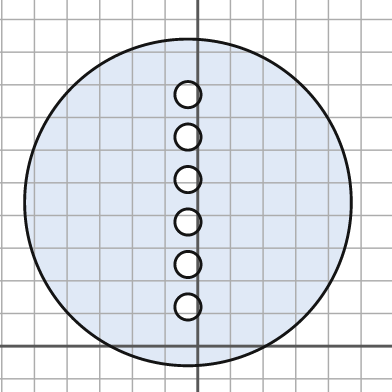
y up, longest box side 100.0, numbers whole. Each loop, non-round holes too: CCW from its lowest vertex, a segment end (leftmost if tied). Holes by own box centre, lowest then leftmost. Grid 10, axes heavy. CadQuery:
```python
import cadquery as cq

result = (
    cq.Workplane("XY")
    .moveTo(-3.0, 44.0)
    .circle(50.0)
    .moveTo(-3.0, 12.0)
    .circle(4.0)
    .moveTo(-3.0, 25.0)
    .circle(4.0)
    .moveTo(-3.0, 38.0)
    .circle(4.0)
    .moveTo(-3.0, 51.0)
    .circle(4.0)
    .moveTo(-3.0, 64.0)
    .circle(4.0)
    .moveTo(-3.0, 77.0)
    .circle(4.0)
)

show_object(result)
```